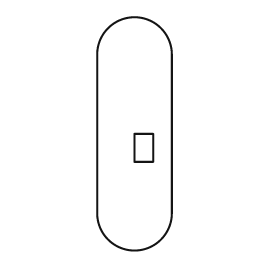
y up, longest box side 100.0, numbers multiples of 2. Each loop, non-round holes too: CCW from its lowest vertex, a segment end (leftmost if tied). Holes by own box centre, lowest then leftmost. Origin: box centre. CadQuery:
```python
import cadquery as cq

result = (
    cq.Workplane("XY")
    .moveTo(-16.0, -34.0)
    .threePointArc((0.0, -50.0), (16.0, -34.0))
    .lineTo(16.0, 34.0)
    .threePointArc((0.0, 50.0), (-16.0, 34.0))
    .close()
    .moveTo(0.0, -12.0)
    .lineTo(8.0, -12.0)
    .lineTo(8.0, 0.0)
    .lineTo(0.0, 0.0)
    .close()
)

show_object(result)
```